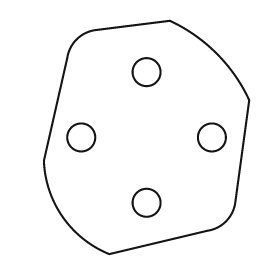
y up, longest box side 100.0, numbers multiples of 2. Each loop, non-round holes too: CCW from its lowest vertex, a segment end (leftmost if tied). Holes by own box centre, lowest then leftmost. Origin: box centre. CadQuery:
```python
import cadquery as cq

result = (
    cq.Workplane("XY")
    .moveTo(-16.0, -50.0)
    .lineTo(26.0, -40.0)
    .threePointArc((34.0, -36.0), (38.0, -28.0))
    .lineTo(44.0, 16.0)
    .threePointArc((30.0, 36.0), (10.0, 50.0))
    .lineTo(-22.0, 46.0)
    .threePointArc((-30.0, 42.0), (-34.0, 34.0))
    .lineTo(-44.0, -10.0)
    .threePointArc((-36.0, -34.0), (-16.0, -50.0))
    .close()
    .moveTo(0.0, -28.0)
    .circle(6.0)
    .moveTo(-28.0, 0.0)
    .circle(6.0)
    .moveTo(28.0, 0.0)
    .circle(6.0)
    .moveTo(0.0, 28.0)
    .circle(6.0)
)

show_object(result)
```